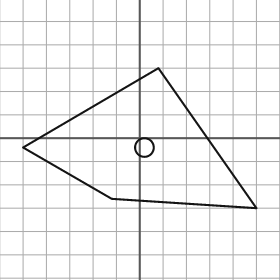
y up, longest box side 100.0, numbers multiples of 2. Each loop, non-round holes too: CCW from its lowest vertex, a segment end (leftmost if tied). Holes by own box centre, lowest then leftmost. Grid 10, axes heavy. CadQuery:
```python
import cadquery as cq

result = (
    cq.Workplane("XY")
    .moveTo(50.0, -30.0)
    .lineTo(8.0, 30.0)
    .lineTo(-50.0, -4.0)
    .lineTo(-12.0, -26.0)
    .close()
    .moveTo(2.0, -4.0)
    .circle(4.0)
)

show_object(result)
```